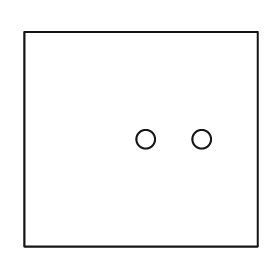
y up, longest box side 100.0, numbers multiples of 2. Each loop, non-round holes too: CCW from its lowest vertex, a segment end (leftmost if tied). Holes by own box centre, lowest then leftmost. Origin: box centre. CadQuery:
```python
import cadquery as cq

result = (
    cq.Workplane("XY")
    .moveTo(-50.0, -46.0)
    .lineTo(50.0, -46.0)
    .lineTo(50.0, 46.0)
    .lineTo(-50.0, 46.0)
    .close()
    .moveTo(2.0, 0.0)
    .circle(4.0)
    .moveTo(26.0, 0.0)
    .circle(4.0)
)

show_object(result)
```